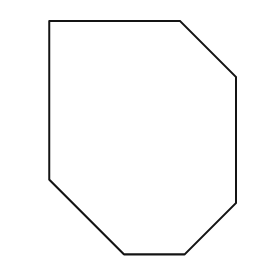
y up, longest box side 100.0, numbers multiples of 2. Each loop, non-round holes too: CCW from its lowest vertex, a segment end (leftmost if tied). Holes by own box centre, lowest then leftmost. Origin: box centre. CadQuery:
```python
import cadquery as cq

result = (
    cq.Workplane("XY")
    .moveTo(-8.0, -50.0)
    .lineTo(18.0, -50.0)
    .lineTo(40.0, -28.0)
    .lineTo(40.0, 26.0)
    .lineTo(16.0, 50.0)
    .lineTo(-40.0, 50.0)
    .lineTo(-40.0, -18.0)
    .close()
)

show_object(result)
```